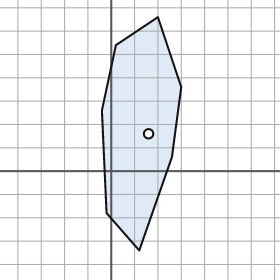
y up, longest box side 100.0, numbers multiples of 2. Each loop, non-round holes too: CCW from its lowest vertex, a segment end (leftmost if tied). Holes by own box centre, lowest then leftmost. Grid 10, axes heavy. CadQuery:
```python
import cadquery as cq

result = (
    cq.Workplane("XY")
    .moveTo(12.0, -34.0)
    .lineTo(26.0, 6.0)
    .lineTo(30.0, 36.0)
    .lineTo(20.0, 66.0)
    .lineTo(2.0, 54.0)
    .lineTo(-4.0, 26.0)
    .lineTo(-2.0, -18.0)
    .close()
    .moveTo(16.0, 16.0)
    .circle(2.0)
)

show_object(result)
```